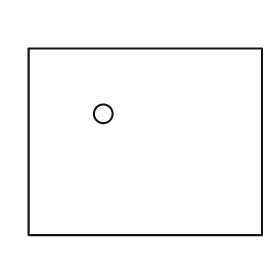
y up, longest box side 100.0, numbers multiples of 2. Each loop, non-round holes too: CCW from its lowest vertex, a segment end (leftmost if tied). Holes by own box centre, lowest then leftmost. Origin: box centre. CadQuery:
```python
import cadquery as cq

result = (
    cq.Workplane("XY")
    .moveTo(-50.0, -40.0)
    .lineTo(50.0, -40.0)
    .lineTo(50.0, 40.0)
    .lineTo(-50.0, 40.0)
    .close()
    .moveTo(-18.0, 12.0)
    .circle(4.0)
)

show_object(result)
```